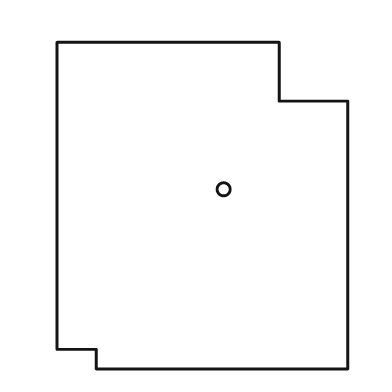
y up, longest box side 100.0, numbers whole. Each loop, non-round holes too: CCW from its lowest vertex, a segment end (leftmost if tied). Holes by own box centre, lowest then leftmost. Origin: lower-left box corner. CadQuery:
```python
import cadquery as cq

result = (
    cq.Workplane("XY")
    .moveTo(12.0, 0.0)
    .lineTo(89.0, 0.0)
    .lineTo(89.0, 82.0)
    .lineTo(68.0, 82.0)
    .lineTo(68.0, 100.0)
    .lineTo(0.0, 100.0)
    .lineTo(0.0, 6.0)
    .lineTo(12.0, 6.0)
    .close()
    .moveTo(51.0, 55.0)
    .circle(2.0)
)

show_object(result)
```